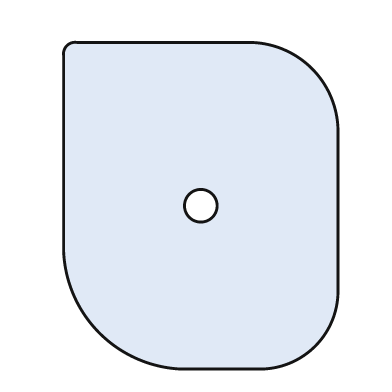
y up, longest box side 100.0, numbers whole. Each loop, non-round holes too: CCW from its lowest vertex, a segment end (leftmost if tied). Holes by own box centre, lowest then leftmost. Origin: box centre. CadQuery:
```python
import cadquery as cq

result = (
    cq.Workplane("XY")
    .moveTo(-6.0, -50.0)
    .lineTo(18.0, -50.0)
    .threePointArc((35.0, -43.0), (42.0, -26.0))
    .lineTo(42.0, 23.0)
    .threePointArc((34.0, 42.0), (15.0, 50.0))
    .lineTo(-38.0, 50.0)
    .threePointArc((-41.0, 49.0), (-42.0, 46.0))
    .lineTo(-42.0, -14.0)
    .threePointArc((-31.0, -39.0), (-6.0, -50.0))
    .close()
    .moveTo(0.0, 0.0)
    .circle(5.0)
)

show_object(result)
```